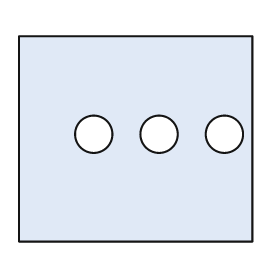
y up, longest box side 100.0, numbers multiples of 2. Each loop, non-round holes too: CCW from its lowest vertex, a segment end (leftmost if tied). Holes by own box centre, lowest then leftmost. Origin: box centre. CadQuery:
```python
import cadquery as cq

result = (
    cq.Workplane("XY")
    .moveTo(-50.0, -44.0)
    .lineTo(50.0, -44.0)
    .lineTo(50.0, 44.0)
    .lineTo(-50.0, 44.0)
    .close()
    .moveTo(-18.0, 2.0)
    .circle(8.0)
    .moveTo(10.0, 2.0)
    .circle(8.0)
    .moveTo(38.0, 2.0)
    .circle(8.0)
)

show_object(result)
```